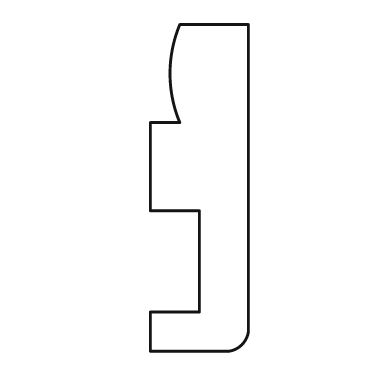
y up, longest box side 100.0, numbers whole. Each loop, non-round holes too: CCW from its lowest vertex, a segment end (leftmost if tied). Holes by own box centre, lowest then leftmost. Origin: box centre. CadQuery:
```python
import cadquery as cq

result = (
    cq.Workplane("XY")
    .moveTo(-15.0, -50.0)
    .lineTo(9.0, -50.0)
    .threePointArc((13.0, -48.0), (15.0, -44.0))
    .lineTo(15.0, 50.0)
    .lineTo(-6.0, 50.0)
    .threePointArc((-9.0, 35.0), (-6.0, 20.0))
    .lineTo(-15.0, 20.0)
    .lineTo(-15.0, -7.0)
    .lineTo(0.0, -7.0)
    .lineTo(0.0, -38.0)
    .lineTo(-15.0, -38.0)
    .close()
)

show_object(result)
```